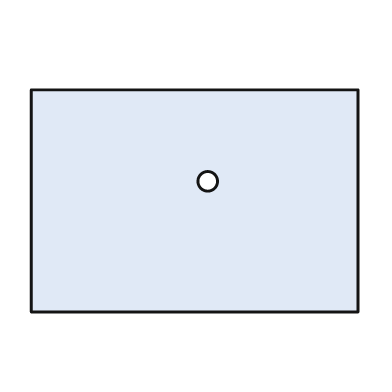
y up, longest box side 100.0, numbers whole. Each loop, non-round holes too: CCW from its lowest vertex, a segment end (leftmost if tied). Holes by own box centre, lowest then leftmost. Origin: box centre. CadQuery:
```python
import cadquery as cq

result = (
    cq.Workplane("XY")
    .moveTo(-50.0, -34.0)
    .lineTo(50.0, -34.0)
    .lineTo(50.0, 34.0)
    .lineTo(-50.0, 34.0)
    .close()
    .moveTo(4.0, 6.0)
    .circle(3.0)
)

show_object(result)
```